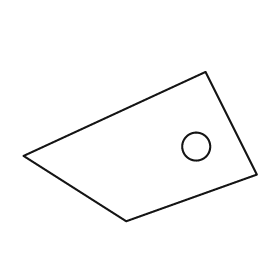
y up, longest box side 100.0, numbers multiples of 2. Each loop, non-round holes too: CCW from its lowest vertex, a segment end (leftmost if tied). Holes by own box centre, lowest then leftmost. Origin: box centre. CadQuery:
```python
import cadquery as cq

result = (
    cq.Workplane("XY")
    .moveTo(-6.0, -32.0)
    .lineTo(50.0, -12.0)
    .lineTo(28.0, 32.0)
    .lineTo(-50.0, -4.0)
    .close()
    .moveTo(24.0, 0.0)
    .circle(6.0)
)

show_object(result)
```